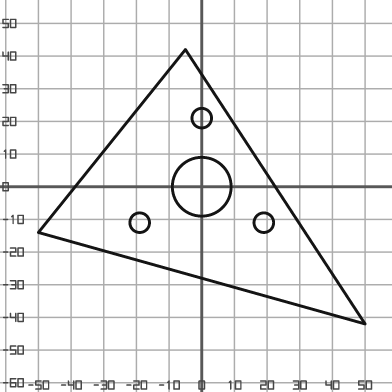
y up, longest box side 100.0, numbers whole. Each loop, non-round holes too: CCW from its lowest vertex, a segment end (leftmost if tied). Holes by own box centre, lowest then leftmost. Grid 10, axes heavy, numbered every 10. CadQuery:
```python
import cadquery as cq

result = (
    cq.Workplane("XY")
    .moveTo(50.0, -42.0)
    .lineTo(-5.0, 42.0)
    .lineTo(-50.0, -14.0)
    .close()
    .moveTo(-19.0, -11.0)
    .circle(3.0)
    .moveTo(19.0, -11.0)
    .circle(3.0)
    .moveTo(0.0, 0.0)
    .circle(9.0)
    .moveTo(0.0, 21.0)
    .circle(3.0)
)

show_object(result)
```